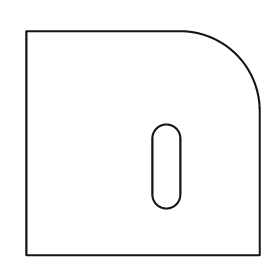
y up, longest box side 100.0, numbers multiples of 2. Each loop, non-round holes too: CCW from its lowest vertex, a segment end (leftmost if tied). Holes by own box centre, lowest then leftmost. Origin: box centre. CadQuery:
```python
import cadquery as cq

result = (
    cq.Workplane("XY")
    .moveTo(-50.0, -48.0)
    .lineTo(50.0, -48.0)
    .lineTo(50.0, 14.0)
    .threePointArc((40.0, 38.0), (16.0, 48.0))
    .lineTo(-50.0, 48.0)
    .close()
    .moveTo(4.0, -22.0)
    .threePointArc((10.0, -28.0), (16.0, -22.0))
    .lineTo(16.0, 2.0)
    .threePointArc((10.0, 8.0), (4.0, 2.0))
    .close()
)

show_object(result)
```